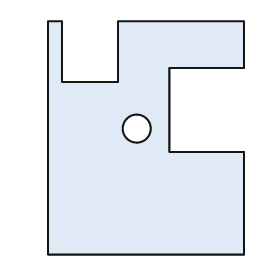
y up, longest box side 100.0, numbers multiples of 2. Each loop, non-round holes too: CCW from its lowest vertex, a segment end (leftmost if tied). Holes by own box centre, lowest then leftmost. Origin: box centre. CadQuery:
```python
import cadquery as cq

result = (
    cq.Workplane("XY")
    .moveTo(-42.0, -50.0)
    .lineTo(42.0, -50.0)
    .lineTo(42.0, -6.0)
    .lineTo(10.0, -6.0)
    .lineTo(10.0, 30.0)
    .lineTo(42.0, 30.0)
    .lineTo(42.0, 50.0)
    .lineTo(-12.0, 50.0)
    .lineTo(-12.0, 24.0)
    .lineTo(-36.0, 24.0)
    .lineTo(-36.0, 50.0)
    .lineTo(-42.0, 50.0)
    .close()
    .moveTo(-4.0, 4.0)
    .circle(6.0)
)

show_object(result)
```